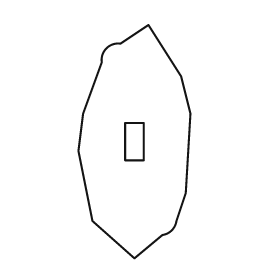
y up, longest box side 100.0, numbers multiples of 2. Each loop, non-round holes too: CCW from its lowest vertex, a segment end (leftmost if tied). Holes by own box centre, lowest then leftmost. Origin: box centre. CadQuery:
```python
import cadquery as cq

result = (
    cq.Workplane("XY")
    .moveTo(0.0, -50.0)
    .lineTo(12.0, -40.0)
    .threePointArc((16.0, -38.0), (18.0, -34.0))
    .lineTo(22.0, -22.0)
    .lineTo(24.0, 12.0)
    .lineTo(20.0, 28.0)
    .lineTo(6.0, 50.0)
    .lineTo(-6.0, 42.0)
    .threePointArc((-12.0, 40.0), (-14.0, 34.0))
    .lineTo(-22.0, 12.0)
    .lineTo(-24.0, -4.0)
    .lineTo(-18.0, -34.0)
    .close()
    .moveTo(-4.0, -8.0)
    .lineTo(4.0, -8.0)
    .lineTo(4.0, 8.0)
    .lineTo(-4.0, 8.0)
    .close()
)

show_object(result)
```